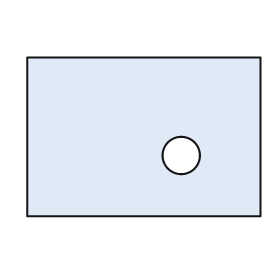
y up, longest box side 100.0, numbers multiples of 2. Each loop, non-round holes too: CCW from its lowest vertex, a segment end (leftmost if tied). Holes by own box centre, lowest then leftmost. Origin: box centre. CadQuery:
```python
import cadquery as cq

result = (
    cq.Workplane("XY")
    .moveTo(-50.0, -34.0)
    .lineTo(50.0, -34.0)
    .lineTo(50.0, 34.0)
    .lineTo(-50.0, 34.0)
    .close()
    .moveTo(16.0, -8.0)
    .circle(8.0)
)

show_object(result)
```